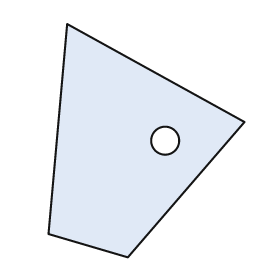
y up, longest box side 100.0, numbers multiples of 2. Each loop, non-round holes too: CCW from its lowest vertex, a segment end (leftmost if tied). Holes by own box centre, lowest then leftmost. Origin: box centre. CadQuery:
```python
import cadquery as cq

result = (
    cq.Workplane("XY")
    .moveTo(-8.0, -50.0)
    .lineTo(42.0, 8.0)
    .lineTo(-34.0, 50.0)
    .lineTo(-42.0, -40.0)
    .close()
    .moveTo(8.0, 0.0)
    .circle(6.0)
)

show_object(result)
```